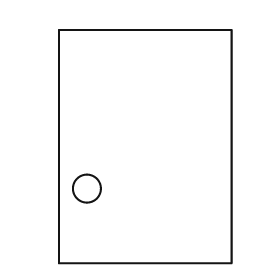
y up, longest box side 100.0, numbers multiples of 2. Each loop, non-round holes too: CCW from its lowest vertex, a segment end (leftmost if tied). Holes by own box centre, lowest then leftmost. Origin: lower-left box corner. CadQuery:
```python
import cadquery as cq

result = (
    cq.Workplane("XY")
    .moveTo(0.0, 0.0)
    .lineTo(74.0, 0.0)
    .lineTo(74.0, 100.0)
    .lineTo(0.0, 100.0)
    .close()
    .moveTo(12.0, 32.0)
    .circle(6.0)
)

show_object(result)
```